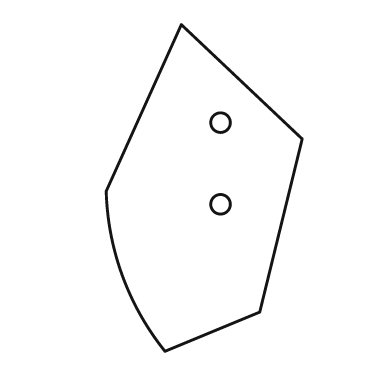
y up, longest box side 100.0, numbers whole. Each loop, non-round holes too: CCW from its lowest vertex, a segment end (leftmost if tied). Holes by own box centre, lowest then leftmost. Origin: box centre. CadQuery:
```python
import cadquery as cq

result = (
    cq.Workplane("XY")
    .moveTo(-12.0, -50.0)
    .lineTo(17.0, -38.0)
    .lineTo(30.0, 15.0)
    .lineTo(-7.0, 50.0)
    .lineTo(-30.0, -1.0)
    .threePointArc((-25.0, -27.0), (-12.0, -50.0))
    .close()
    .moveTo(5.0, -5.0)
    .circle(3.0)
    .moveTo(5.0, 20.0)
    .circle(3.0)
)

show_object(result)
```